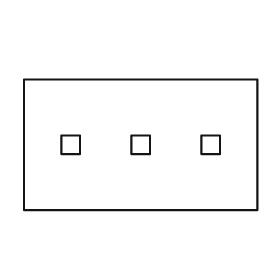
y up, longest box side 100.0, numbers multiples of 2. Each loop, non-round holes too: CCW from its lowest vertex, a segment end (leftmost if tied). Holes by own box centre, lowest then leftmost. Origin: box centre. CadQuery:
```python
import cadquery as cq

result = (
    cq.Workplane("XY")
    .moveTo(-50.0, -28.0)
    .lineTo(50.0, -28.0)
    .lineTo(50.0, 28.0)
    .lineTo(-50.0, 28.0)
    .close()
    .moveTo(-34.0, -4.0)
    .lineTo(-26.0, -4.0)
    .lineTo(-26.0, 4.0)
    .lineTo(-34.0, 4.0)
    .close()
    .moveTo(-4.0, -4.0)
    .lineTo(4.0, -4.0)
    .lineTo(4.0, 4.0)
    .lineTo(-4.0, 4.0)
    .close()
    .moveTo(26.0, -4.0)
    .lineTo(34.0, -4.0)
    .lineTo(34.0, 4.0)
    .lineTo(26.0, 4.0)
    .close()
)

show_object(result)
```